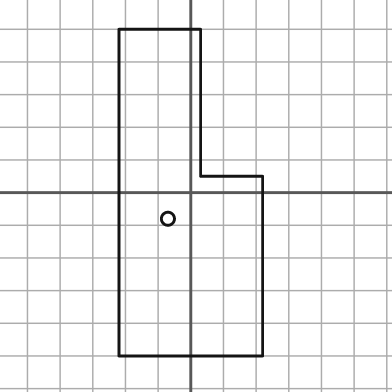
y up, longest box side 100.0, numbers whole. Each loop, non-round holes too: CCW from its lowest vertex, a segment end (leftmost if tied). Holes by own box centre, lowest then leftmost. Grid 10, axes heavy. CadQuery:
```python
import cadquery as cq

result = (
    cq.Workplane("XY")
    .moveTo(-22.0, -50.0)
    .lineTo(22.0, -50.0)
    .lineTo(22.0, 5.0)
    .lineTo(3.0, 5.0)
    .lineTo(3.0, 50.0)
    .lineTo(-22.0, 50.0)
    .close()
    .moveTo(-7.0, -8.0)
    .circle(2.0)
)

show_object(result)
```